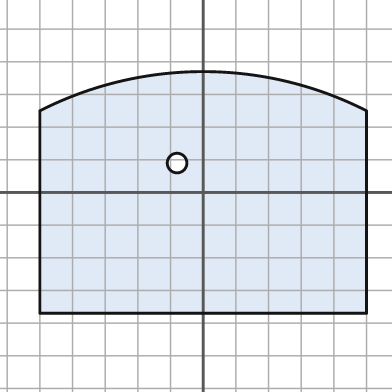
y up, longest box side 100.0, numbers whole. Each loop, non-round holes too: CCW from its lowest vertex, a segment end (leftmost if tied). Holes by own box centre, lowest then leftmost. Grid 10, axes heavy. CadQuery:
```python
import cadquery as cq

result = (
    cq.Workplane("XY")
    .moveTo(-50.0, -37.0)
    .lineTo(50.0, -37.0)
    .lineTo(50.0, 25.0)
    .threePointArc((0.0, 37.0), (-50.0, 25.0))
    .close()
    .moveTo(-8.0, 9.0)
    .circle(3.0)
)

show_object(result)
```